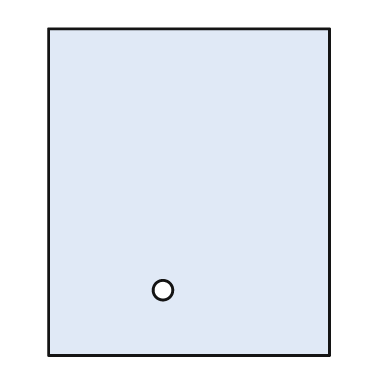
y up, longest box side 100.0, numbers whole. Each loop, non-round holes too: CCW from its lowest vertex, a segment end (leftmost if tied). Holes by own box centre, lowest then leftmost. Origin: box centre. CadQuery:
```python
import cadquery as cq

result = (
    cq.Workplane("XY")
    .moveTo(-43.0, -50.0)
    .lineTo(43.0, -50.0)
    .lineTo(43.0, 50.0)
    .lineTo(-43.0, 50.0)
    .close()
    .moveTo(-8.0, -30.0)
    .circle(3.0)
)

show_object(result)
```